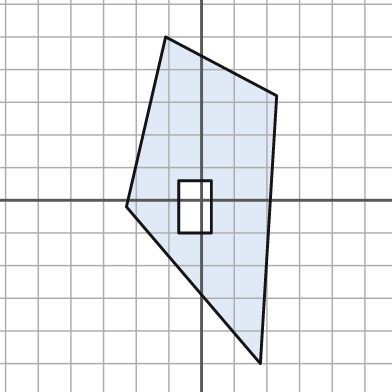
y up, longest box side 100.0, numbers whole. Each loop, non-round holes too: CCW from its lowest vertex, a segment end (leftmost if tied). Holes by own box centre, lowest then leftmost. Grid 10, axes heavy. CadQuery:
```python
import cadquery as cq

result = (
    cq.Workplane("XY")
    .moveTo(18.0, -50.0)
    .lineTo(23.0, 32.0)
    .lineTo(-11.0, 50.0)
    .lineTo(-23.0, -2.0)
    .close()
    .moveTo(-7.0, -10.0)
    .lineTo(3.0, -10.0)
    .lineTo(3.0, 6.0)
    .lineTo(-7.0, 6.0)
    .close()
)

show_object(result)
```